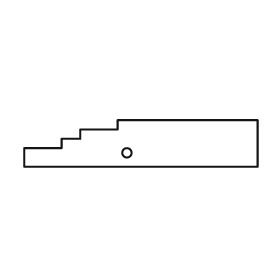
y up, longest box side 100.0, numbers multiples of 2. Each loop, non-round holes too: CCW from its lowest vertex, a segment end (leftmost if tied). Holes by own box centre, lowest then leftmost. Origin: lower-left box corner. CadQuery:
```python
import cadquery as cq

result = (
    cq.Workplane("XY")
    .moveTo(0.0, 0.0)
    .lineTo(100.0, 0.0)
    .lineTo(100.0, 20.0)
    .lineTo(40.0, 20.0)
    .lineTo(40.0, 16.0)
    .lineTo(24.0, 16.0)
    .lineTo(24.0, 12.0)
    .lineTo(16.0, 12.0)
    .lineTo(16.0, 8.0)
    .lineTo(0.0, 8.0)
    .close()
    .moveTo(44.0, 6.0)
    .circle(2.0)
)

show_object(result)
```